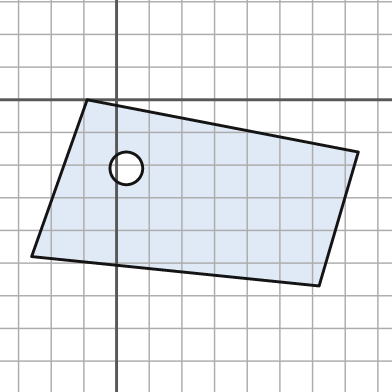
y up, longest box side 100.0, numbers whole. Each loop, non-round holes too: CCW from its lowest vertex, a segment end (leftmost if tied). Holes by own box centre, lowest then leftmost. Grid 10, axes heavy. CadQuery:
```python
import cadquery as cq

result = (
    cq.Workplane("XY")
    .moveTo(62.0, -57.0)
    .lineTo(74.0, -16.0)
    .lineTo(-9.0, 0.0)
    .lineTo(-26.0, -48.0)
    .close()
    .moveTo(3.0, -21.0)
    .circle(5.0)
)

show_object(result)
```